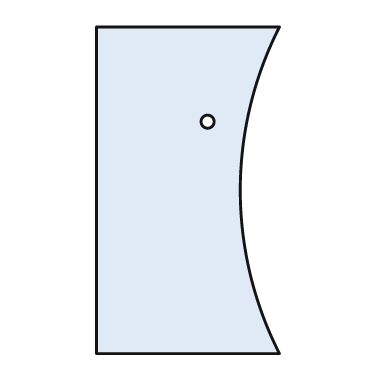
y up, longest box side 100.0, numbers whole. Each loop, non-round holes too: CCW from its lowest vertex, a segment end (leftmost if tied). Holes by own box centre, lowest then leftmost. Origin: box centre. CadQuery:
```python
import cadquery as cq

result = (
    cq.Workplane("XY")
    .moveTo(-28.0, -50.0)
    .lineTo(28.0, -50.0)
    .threePointArc((16.0, 0.0), (28.0, 50.0))
    .lineTo(-28.0, 50.0)
    .close()
    .moveTo(6.0, 21.0)
    .circle(2.0)
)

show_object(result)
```